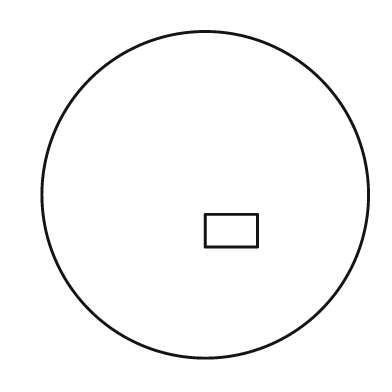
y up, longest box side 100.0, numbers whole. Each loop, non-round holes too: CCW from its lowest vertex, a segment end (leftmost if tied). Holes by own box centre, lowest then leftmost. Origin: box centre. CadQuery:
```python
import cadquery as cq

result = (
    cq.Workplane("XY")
    .moveTo(0.0, 0.0)
    .circle(50.0)
    .moveTo(0.0, -16.0)
    .lineTo(16.0, -16.0)
    .lineTo(16.0, -6.0)
    .lineTo(0.0, -6.0)
    .close()
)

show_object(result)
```